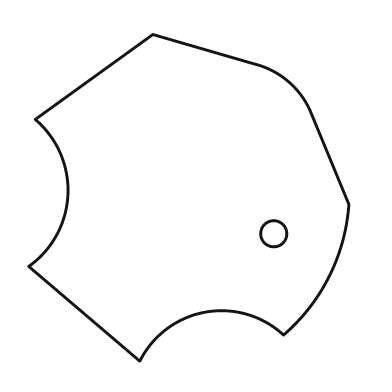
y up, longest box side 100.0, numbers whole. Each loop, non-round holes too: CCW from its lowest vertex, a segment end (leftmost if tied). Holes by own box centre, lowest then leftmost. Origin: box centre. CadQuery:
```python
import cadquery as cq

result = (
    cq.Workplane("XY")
    .moveTo(-15.0, -50.0)
    .threePointArc((5.0, -35.0), (29.0, -42.0))
    .threePointArc((43.0, -24.0), (49.0, -2.0))
    .lineTo(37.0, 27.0)
    .threePointArc((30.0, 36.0), (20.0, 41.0))
    .lineTo(-11.0, 50.0)
    .lineTo(-47.0, 24.0)
    .threePointArc((-37.0, 1.0), (-49.0, -21.0))
    .close()
    .moveTo(26.0, -11.0)
    .circle(4.0)
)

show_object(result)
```